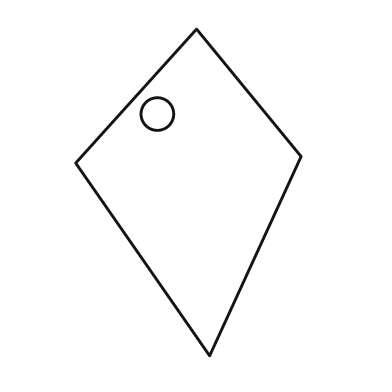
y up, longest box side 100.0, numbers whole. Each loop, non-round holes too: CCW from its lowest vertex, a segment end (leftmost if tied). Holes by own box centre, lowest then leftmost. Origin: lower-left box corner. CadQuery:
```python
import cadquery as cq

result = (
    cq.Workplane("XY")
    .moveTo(41.0, 0.0)
    .lineTo(69.0, 61.0)
    .lineTo(37.0, 100.0)
    .lineTo(0.0, 59.0)
    .close()
    .moveTo(25.0, 74.0)
    .circle(5.0)
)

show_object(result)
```